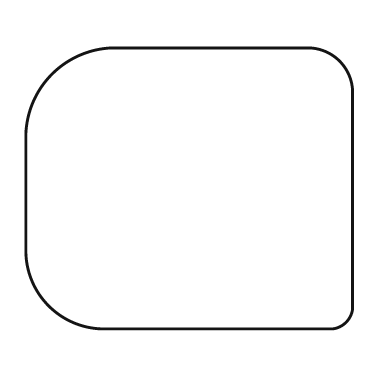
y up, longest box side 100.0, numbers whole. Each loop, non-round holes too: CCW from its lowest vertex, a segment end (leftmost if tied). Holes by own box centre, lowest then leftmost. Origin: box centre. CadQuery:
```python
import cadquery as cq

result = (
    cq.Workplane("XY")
    .moveTo(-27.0, -43.0)
    .lineTo(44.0, -43.0)
    .threePointArc((48.0, -41.0), (50.0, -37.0))
    .lineTo(50.0, 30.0)
    .threePointArc((46.0, 39.0), (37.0, 43.0))
    .lineTo(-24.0, 43.0)
    .threePointArc((-42.0, 35.0), (-50.0, 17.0))
    .lineTo(-50.0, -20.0)
    .threePointArc((-43.0, -36.0), (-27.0, -43.0))
    .close()
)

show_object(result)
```